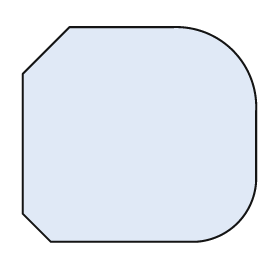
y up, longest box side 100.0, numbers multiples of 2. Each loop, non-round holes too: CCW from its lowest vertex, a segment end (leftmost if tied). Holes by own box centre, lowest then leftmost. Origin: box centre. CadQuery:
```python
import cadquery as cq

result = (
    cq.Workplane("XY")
    .moveTo(-38.0, -46.0)
    .lineTo(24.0, -46.0)
    .threePointArc((42.0, -38.0), (50.0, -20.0))
    .lineTo(50.0, 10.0)
    .threePointArc((40.0, 36.0), (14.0, 46.0))
    .lineTo(-30.0, 46.0)
    .lineTo(-50.0, 26.0)
    .lineTo(-50.0, -34.0)
    .close()
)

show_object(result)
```